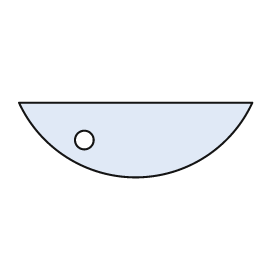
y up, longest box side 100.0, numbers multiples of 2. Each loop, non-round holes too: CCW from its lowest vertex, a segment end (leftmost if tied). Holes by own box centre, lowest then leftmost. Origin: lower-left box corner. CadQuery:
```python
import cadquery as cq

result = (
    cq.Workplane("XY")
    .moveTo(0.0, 32.0)
    .threePointArc((50.0, 0.0), (100.0, 32.0))
    .close()
    .moveTo(28.0, 16.0)
    .circle(4.0)
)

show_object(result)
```